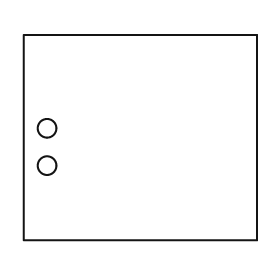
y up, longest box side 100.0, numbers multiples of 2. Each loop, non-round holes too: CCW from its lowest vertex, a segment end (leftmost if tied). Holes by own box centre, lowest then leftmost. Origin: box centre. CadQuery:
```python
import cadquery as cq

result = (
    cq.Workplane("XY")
    .moveTo(-50.0, -44.0)
    .lineTo(50.0, -44.0)
    .lineTo(50.0, 44.0)
    .lineTo(-50.0, 44.0)
    .close()
    .moveTo(-40.0, -12.0)
    .circle(4.0)
    .moveTo(-40.0, 4.0)
    .circle(4.0)
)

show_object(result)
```